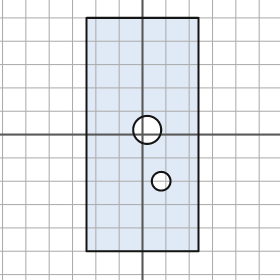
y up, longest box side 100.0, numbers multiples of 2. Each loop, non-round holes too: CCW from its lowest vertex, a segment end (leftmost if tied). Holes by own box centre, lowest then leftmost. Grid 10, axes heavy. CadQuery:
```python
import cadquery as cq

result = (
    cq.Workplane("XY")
    .moveTo(-24.0, -50.0)
    .lineTo(24.0, -50.0)
    .lineTo(24.0, 50.0)
    .lineTo(-24.0, 50.0)
    .close()
    .moveTo(8.0, -20.0)
    .circle(4.0)
    .moveTo(2.0, 2.0)
    .circle(6.0)
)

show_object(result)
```